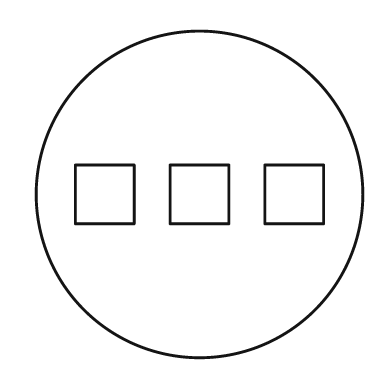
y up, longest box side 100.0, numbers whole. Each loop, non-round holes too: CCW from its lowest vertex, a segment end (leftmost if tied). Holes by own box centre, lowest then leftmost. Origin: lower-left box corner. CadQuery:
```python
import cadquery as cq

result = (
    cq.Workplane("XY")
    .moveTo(50.0, 50.0)
    .circle(50.0)
    .moveTo(12.0, 41.0)
    .lineTo(30.0, 41.0)
    .lineTo(30.0, 59.0)
    .lineTo(12.0, 59.0)
    .close()
    .moveTo(41.0, 41.0)
    .lineTo(59.0, 41.0)
    .lineTo(59.0, 59.0)
    .lineTo(41.0, 59.0)
    .close()
    .moveTo(70.0, 41.0)
    .lineTo(88.0, 41.0)
    .lineTo(88.0, 59.0)
    .lineTo(70.0, 59.0)
    .close()
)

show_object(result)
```